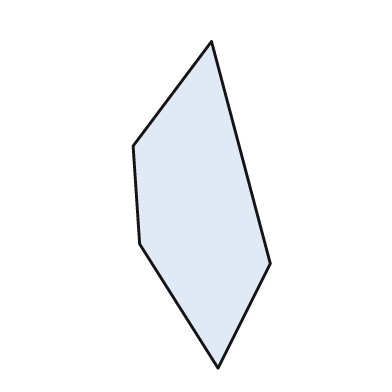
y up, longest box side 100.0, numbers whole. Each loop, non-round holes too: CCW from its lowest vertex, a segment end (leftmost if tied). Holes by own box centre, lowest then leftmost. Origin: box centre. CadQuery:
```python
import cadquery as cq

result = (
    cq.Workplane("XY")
    .moveTo(5.0, -50.0)
    .lineTo(21.0, -18.0)
    .lineTo(3.0, 50.0)
    .lineTo(-21.0, 18.0)
    .lineTo(-19.0, -12.0)
    .close()
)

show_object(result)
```